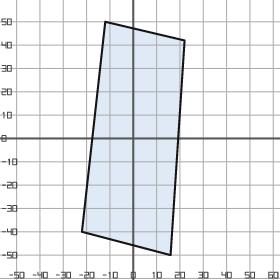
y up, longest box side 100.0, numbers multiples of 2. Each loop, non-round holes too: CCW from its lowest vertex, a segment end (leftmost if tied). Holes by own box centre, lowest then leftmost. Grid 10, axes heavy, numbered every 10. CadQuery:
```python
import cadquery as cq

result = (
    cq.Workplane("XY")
    .moveTo(16.0, -50.0)
    .lineTo(22.0, 42.0)
    .lineTo(-12.0, 50.0)
    .lineTo(-22.0, -40.0)
    .close()
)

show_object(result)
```